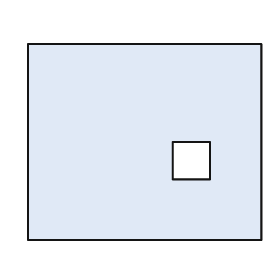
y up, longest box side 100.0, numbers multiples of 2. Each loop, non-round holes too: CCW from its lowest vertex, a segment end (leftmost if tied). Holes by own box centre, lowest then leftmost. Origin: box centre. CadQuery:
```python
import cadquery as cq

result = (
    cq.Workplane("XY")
    .moveTo(-50.0, -42.0)
    .lineTo(50.0, -42.0)
    .lineTo(50.0, 42.0)
    .lineTo(-50.0, 42.0)
    .close()
    .moveTo(12.0, -16.0)
    .lineTo(28.0, -16.0)
    .lineTo(28.0, 0.0)
    .lineTo(12.0, 0.0)
    .close()
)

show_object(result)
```